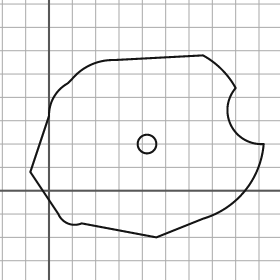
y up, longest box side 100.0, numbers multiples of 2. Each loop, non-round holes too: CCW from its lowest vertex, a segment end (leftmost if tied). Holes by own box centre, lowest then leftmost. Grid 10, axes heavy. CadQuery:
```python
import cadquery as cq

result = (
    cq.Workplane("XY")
    .moveTo(46.0, -20.0)
    .lineTo(66.0, -12.0)
    .threePointArc((84.0, 0.0), (92.0, 20.0))
    .threePointArc((78.0, 28.0), (80.0, 44.0))
    .threePointArc((74.0, 52.0), (66.0, 58.0))
    .lineTo(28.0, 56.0)
    .threePointArc((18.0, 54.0), (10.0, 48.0))
    .lineTo(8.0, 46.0)
    .threePointArc((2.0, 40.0), (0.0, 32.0))
    .lineTo(-8.0, 8.0)
    .lineTo(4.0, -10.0)
    .threePointArc((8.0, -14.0), (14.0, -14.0))
    .close()
    .moveTo(42.0, 20.0)
    .circle(4.0)
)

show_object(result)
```